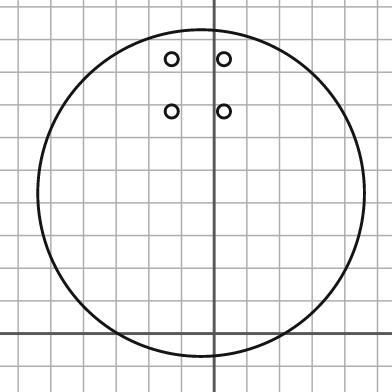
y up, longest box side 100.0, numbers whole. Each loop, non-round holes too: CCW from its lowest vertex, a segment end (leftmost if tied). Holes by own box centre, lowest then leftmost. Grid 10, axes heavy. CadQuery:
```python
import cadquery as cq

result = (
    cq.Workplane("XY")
    .moveTo(-4.0, 43.0)
    .circle(50.0)
    .moveTo(-13.0, 68.0)
    .circle(2.0)
    .moveTo(3.0, 68.0)
    .circle(2.0)
    .moveTo(-13.0, 84.0)
    .circle(2.0)
    .moveTo(3.0, 84.0)
    .circle(2.0)
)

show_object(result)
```